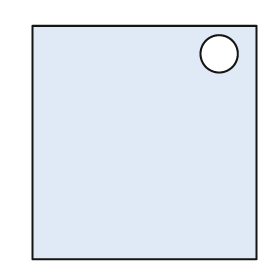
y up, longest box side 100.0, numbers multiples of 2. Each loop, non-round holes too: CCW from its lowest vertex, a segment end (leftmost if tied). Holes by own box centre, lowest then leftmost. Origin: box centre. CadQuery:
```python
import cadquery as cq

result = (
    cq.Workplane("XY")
    .moveTo(-48.0, -50.0)
    .lineTo(48.0, -50.0)
    .lineTo(48.0, 50.0)
    .lineTo(-48.0, 50.0)
    .close()
    .moveTo(32.0, 38.0)
    .circle(8.0)
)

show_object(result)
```